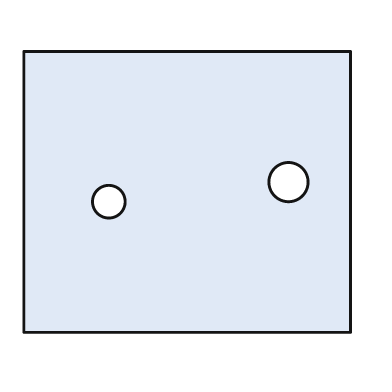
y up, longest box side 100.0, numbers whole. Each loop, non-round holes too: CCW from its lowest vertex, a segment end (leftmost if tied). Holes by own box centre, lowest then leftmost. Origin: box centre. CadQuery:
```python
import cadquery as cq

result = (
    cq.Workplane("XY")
    .moveTo(-50.0, -43.0)
    .lineTo(50.0, -43.0)
    .lineTo(50.0, 43.0)
    .lineTo(-50.0, 43.0)
    .close()
    .moveTo(-24.0, -3.0)
    .circle(5.0)
    .moveTo(31.0, 3.0)
    .circle(6.0)
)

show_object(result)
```